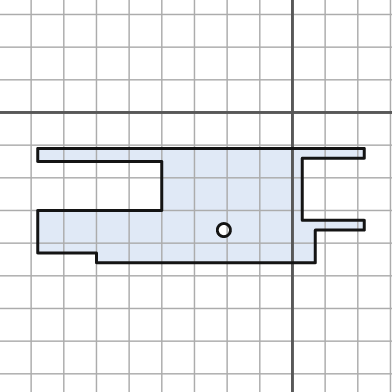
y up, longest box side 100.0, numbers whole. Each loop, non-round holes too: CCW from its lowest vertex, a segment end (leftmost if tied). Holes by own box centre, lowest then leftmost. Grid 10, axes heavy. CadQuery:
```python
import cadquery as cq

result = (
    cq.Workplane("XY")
    .moveTo(-60.0, -46.0)
    .lineTo(7.0, -46.0)
    .lineTo(7.0, -36.0)
    .lineTo(22.0, -36.0)
    .lineTo(22.0, -33.0)
    .lineTo(3.0, -33.0)
    .lineTo(3.0, -14.0)
    .lineTo(22.0, -14.0)
    .lineTo(22.0, -11.0)
    .lineTo(-78.0, -11.0)
    .lineTo(-78.0, -15.0)
    .lineTo(-40.0, -15.0)
    .lineTo(-40.0, -30.0)
    .lineTo(-78.0, -30.0)
    .lineTo(-78.0, -43.0)
    .lineTo(-60.0, -43.0)
    .close()
    .moveTo(-21.0, -36.0)
    .circle(2.0)
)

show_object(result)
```